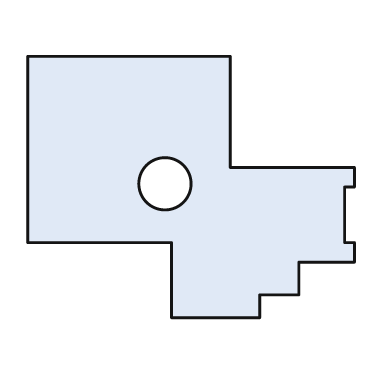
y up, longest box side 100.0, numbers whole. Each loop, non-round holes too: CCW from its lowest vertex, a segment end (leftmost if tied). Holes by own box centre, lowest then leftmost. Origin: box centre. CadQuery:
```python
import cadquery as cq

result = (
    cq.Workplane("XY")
    .moveTo(-6.0, -40.0)
    .lineTo(21.0, -40.0)
    .lineTo(21.0, -33.0)
    .lineTo(33.0, -33.0)
    .lineTo(33.0, -23.0)
    .lineTo(50.0, -23.0)
    .lineTo(50.0, -17.0)
    .lineTo(47.0, -17.0)
    .lineTo(47.0, 0.0)
    .lineTo(50.0, 0.0)
    .lineTo(50.0, 6.0)
    .lineTo(12.0, 6.0)
    .lineTo(12.0, 40.0)
    .lineTo(-50.0, 40.0)
    .lineTo(-50.0, -17.0)
    .lineTo(-6.0, -17.0)
    .close()
    .moveTo(-8.0, 1.0)
    .circle(8.0)
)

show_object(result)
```